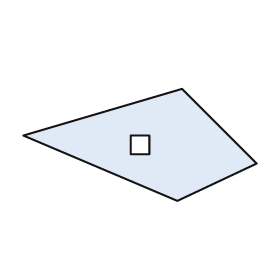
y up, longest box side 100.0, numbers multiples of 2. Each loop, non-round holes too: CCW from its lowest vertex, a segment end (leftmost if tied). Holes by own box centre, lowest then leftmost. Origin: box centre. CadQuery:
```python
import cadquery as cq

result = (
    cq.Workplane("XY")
    .moveTo(16.0, -24.0)
    .lineTo(50.0, -8.0)
    .lineTo(18.0, 24.0)
    .lineTo(-50.0, 4.0)
    .close()
    .moveTo(-4.0, -4.0)
    .lineTo(4.0, -4.0)
    .lineTo(4.0, 4.0)
    .lineTo(-4.0, 4.0)
    .close()
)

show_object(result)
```